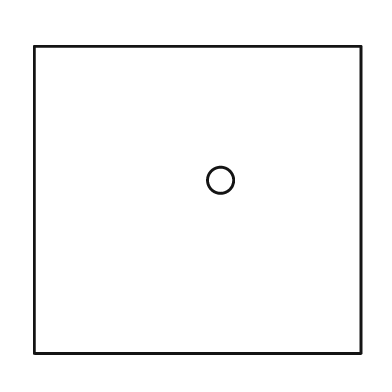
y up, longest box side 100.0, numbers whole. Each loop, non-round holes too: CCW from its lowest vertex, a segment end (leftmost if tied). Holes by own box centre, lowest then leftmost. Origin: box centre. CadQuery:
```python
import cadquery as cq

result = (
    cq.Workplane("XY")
    .moveTo(-50.0, -47.0)
    .lineTo(50.0, -47.0)
    .lineTo(50.0, 47.0)
    .lineTo(-50.0, 47.0)
    .close()
    .moveTo(7.0, 6.0)
    .circle(4.0)
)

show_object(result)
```